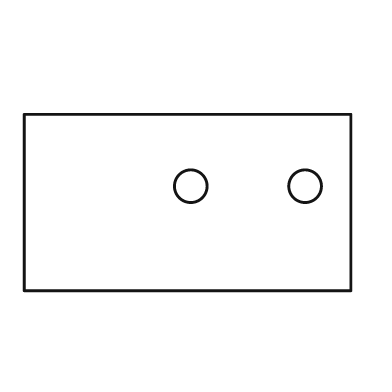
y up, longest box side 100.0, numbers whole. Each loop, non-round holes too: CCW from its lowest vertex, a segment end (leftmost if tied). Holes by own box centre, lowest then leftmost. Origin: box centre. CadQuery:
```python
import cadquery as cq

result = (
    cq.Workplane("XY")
    .moveTo(-50.0, -27.0)
    .lineTo(50.0, -27.0)
    .lineTo(50.0, 27.0)
    .lineTo(-50.0, 27.0)
    .close()
    .moveTo(1.0, 5.0)
    .circle(5.0)
    .moveTo(36.0, 5.0)
    .circle(5.0)
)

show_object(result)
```